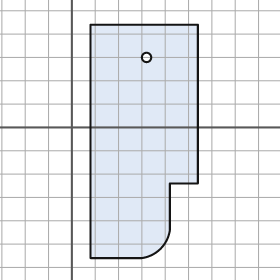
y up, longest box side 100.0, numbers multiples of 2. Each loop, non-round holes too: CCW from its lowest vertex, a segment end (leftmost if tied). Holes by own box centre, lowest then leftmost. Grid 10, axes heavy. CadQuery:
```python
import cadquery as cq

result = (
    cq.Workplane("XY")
    .moveTo(8.0, -56.0)
    .lineTo(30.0, -56.0)
    .threePointArc((38.0, -52.0), (42.0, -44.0))
    .lineTo(42.0, -24.0)
    .lineTo(54.0, -24.0)
    .lineTo(54.0, 44.0)
    .lineTo(8.0, 44.0)
    .close()
    .moveTo(32.0, 30.0)
    .circle(2.0)
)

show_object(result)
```